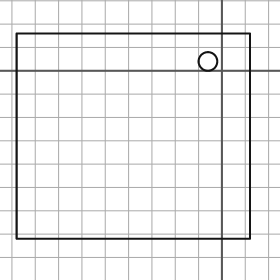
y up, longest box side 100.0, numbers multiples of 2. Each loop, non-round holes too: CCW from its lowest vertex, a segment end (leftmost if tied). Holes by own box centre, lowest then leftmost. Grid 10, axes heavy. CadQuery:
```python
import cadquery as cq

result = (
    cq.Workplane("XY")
    .moveTo(-88.0, -72.0)
    .lineTo(12.0, -72.0)
    .lineTo(12.0, 16.0)
    .lineTo(-88.0, 16.0)
    .close()
    .moveTo(-6.0, 4.0)
    .circle(4.0)
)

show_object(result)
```